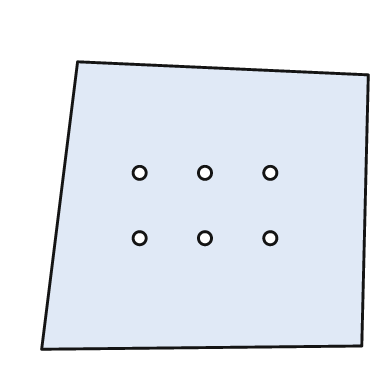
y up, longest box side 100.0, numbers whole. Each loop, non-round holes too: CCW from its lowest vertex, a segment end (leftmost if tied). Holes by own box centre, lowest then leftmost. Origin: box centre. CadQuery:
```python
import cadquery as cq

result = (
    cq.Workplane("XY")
    .moveTo(-50.0, -44.0)
    .lineTo(48.0, -43.0)
    .lineTo(50.0, 40.0)
    .lineTo(-39.0, 44.0)
    .close()
    .moveTo(-20.0, -10.0)
    .circle(2.0)
    .moveTo(0.0, -10.0)
    .circle(2.0)
    .moveTo(20.0, -10.0)
    .circle(2.0)
    .moveTo(-20.0, 10.0)
    .circle(2.0)
    .moveTo(0.0, 10.0)
    .circle(2.0)
    .moveTo(20.0, 10.0)
    .circle(2.0)
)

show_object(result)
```